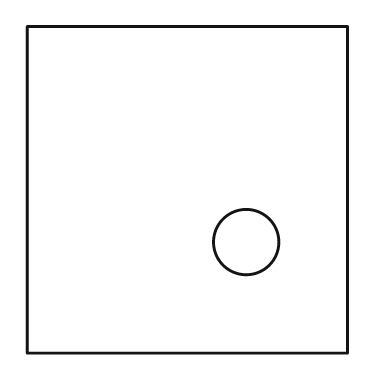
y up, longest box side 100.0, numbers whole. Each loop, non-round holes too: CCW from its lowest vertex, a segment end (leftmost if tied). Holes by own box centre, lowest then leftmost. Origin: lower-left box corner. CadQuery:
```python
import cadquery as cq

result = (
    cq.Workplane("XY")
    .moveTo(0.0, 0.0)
    .lineTo(98.0, 0.0)
    .lineTo(98.0, 100.0)
    .lineTo(0.0, 100.0)
    .close()
    .moveTo(67.0, 34.0)
    .circle(10.0)
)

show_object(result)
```